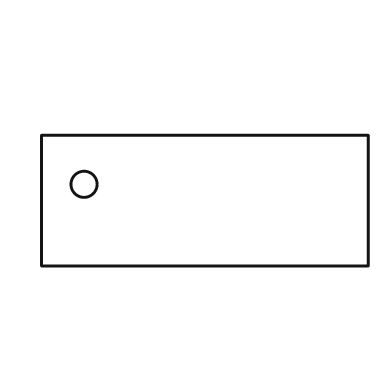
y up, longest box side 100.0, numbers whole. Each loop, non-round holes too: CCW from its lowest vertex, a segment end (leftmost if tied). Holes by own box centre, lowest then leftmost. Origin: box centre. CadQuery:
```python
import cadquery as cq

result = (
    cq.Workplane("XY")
    .moveTo(-50.0, -20.0)
    .lineTo(50.0, -20.0)
    .lineTo(50.0, 20.0)
    .lineTo(-50.0, 20.0)
    .close()
    .moveTo(-37.0, 5.0)
    .circle(4.0)
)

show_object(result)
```